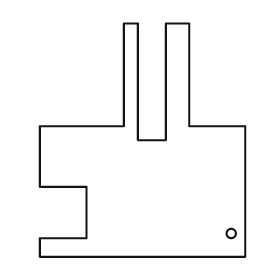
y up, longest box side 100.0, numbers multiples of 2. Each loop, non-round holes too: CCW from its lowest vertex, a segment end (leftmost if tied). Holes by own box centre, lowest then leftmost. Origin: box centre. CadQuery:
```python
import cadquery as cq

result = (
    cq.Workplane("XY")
    .moveTo(-44.0, -50.0)
    .lineTo(44.0, -50.0)
    .lineTo(44.0, 6.0)
    .lineTo(20.0, 6.0)
    .lineTo(20.0, 50.0)
    .lineTo(10.0, 50.0)
    .lineTo(10.0, 0.0)
    .lineTo(-2.0, 0.0)
    .lineTo(-2.0, 50.0)
    .lineTo(-8.0, 50.0)
    .lineTo(-8.0, 6.0)
    .lineTo(-44.0, 6.0)
    .lineTo(-44.0, -20.0)
    .lineTo(-24.0, -20.0)
    .lineTo(-24.0, -42.0)
    .lineTo(-44.0, -42.0)
    .close()
    .moveTo(38.0, -40.0)
    .circle(2.0)
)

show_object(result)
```